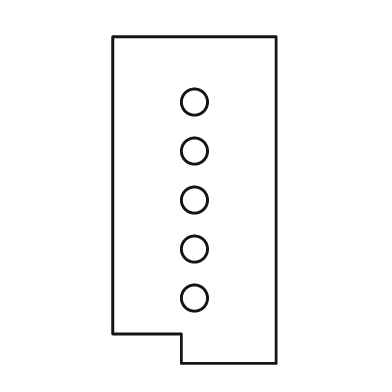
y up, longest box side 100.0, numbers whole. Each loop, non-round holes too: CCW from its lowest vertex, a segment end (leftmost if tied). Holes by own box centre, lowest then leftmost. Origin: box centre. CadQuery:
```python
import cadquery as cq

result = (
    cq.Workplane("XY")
    .moveTo(-4.0, -50.0)
    .lineTo(25.0, -50.0)
    .lineTo(25.0, 50.0)
    .lineTo(-25.0, 50.0)
    .lineTo(-25.0, -41.0)
    .lineTo(-4.0, -41.0)
    .close()
    .moveTo(0.0, -30.0)
    .circle(4.0)
    .moveTo(0.0, -15.0)
    .circle(4.0)
    .moveTo(0.0, 0.0)
    .circle(4.0)
    .moveTo(0.0, 15.0)
    .circle(4.0)
    .moveTo(0.0, 30.0)
    .circle(4.0)
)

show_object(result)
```